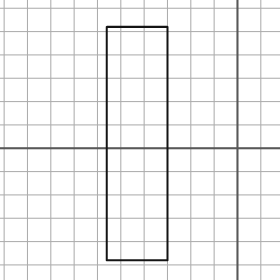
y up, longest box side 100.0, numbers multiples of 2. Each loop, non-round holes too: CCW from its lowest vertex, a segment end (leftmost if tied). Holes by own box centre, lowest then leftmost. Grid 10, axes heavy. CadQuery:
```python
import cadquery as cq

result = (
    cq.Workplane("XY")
    .moveTo(-56.0, -48.0)
    .lineTo(-30.0, -48.0)
    .lineTo(-30.0, 52.0)
    .lineTo(-56.0, 52.0)
    .close()
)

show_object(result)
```